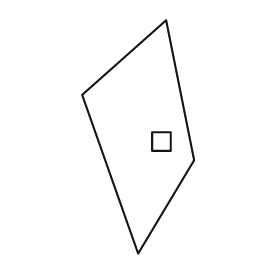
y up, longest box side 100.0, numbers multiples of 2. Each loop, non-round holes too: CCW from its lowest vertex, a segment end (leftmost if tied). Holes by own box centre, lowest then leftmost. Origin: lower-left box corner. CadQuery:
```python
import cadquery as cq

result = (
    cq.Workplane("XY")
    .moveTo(24.0, 0.0)
    .lineTo(48.0, 40.0)
    .lineTo(36.0, 100.0)
    .lineTo(0.0, 68.0)
    .close()
    .moveTo(30.0, 44.0)
    .lineTo(38.0, 44.0)
    .lineTo(38.0, 52.0)
    .lineTo(30.0, 52.0)
    .close()
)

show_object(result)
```